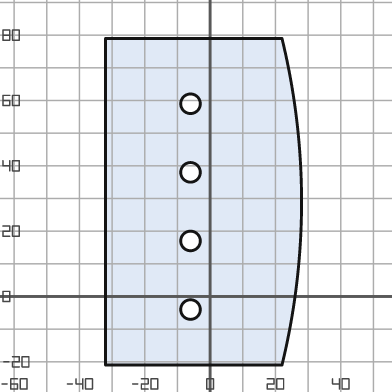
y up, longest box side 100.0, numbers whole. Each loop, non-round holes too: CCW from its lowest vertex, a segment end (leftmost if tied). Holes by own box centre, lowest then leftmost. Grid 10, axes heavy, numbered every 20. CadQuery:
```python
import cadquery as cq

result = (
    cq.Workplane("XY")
    .moveTo(-32.0, -21.0)
    .lineTo(22.0, -21.0)
    .threePointArc((28.0, 29.0), (22.0, 79.0))
    .lineTo(-32.0, 79.0)
    .close()
    .moveTo(-6.0, -4.0)
    .circle(3.0)
    .moveTo(-6.0, 17.0)
    .circle(3.0)
    .moveTo(-6.0, 38.0)
    .circle(3.0)
    .moveTo(-6.0, 59.0)
    .circle(3.0)
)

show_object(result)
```